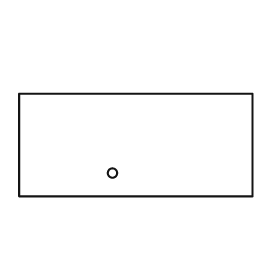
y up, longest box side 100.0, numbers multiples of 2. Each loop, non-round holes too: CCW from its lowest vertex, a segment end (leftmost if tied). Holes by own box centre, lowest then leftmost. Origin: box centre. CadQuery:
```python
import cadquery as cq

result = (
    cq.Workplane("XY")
    .moveTo(-50.0, -22.0)
    .lineTo(50.0, -22.0)
    .lineTo(50.0, 22.0)
    .lineTo(-50.0, 22.0)
    .close()
    .moveTo(-10.0, -12.0)
    .circle(2.0)
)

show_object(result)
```